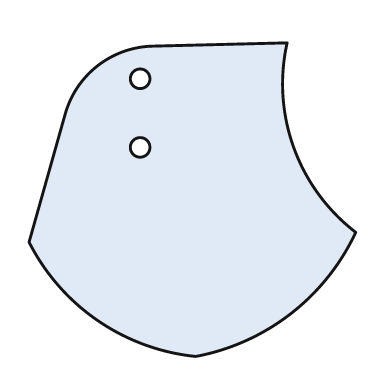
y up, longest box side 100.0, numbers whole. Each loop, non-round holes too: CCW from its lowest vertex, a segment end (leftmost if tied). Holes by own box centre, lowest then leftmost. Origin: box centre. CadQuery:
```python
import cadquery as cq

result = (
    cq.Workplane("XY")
    .moveTo(1.0, -48.0)
    .threePointArc((30.0, -35.0), (50.0, -10.0))
    .threePointArc((31.0, 16.0), (29.0, 48.0))
    .lineTo(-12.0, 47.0)
    .threePointArc((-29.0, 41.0), (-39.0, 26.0))
    .lineTo(-50.0, -13.0)
    .threePointArc((-29.0, -37.0), (1.0, -48.0))
    .close()
    .moveTo(-16.0, 16.0)
    .circle(3.0)
    .moveTo(-16.0, 37.0)
    .circle(3.0)
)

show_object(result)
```